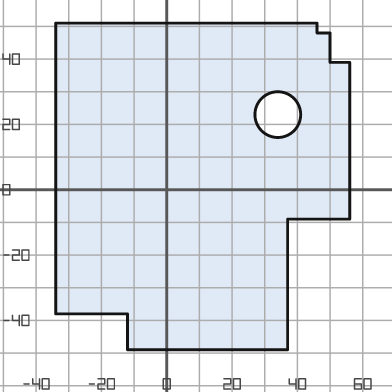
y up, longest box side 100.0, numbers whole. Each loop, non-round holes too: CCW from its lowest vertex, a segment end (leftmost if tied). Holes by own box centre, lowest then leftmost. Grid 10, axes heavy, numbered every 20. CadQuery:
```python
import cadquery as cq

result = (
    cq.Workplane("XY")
    .moveTo(-12.0, -49.0)
    .lineTo(37.0, -49.0)
    .lineTo(37.0, -9.0)
    .lineTo(56.0, -9.0)
    .lineTo(56.0, 39.0)
    .lineTo(50.0, 39.0)
    .lineTo(50.0, 48.0)
    .lineTo(46.0, 48.0)
    .lineTo(46.0, 51.0)
    .lineTo(-34.0, 51.0)
    .lineTo(-34.0, -38.0)
    .lineTo(-12.0, -38.0)
    .close()
    .moveTo(34.0, 23.0)
    .circle(7.0)
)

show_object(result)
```